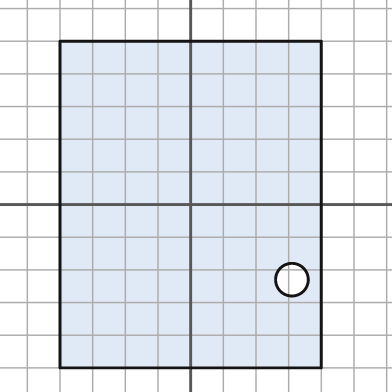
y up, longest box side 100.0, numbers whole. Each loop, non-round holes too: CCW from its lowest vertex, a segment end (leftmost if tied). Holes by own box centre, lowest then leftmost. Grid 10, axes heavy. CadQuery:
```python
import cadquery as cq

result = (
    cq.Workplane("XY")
    .moveTo(-40.0, -50.0)
    .lineTo(40.0, -50.0)
    .lineTo(40.0, 50.0)
    .lineTo(-40.0, 50.0)
    .close()
    .moveTo(31.0, -23.0)
    .circle(5.0)
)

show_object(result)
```